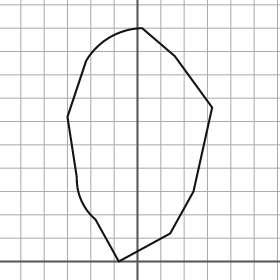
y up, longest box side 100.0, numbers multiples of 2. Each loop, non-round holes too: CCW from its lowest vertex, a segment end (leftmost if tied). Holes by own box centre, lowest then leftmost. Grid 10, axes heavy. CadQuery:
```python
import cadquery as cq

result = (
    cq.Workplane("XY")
    .moveTo(-8.0, 0.0)
    .lineTo(14.0, 12.0)
    .lineTo(24.0, 30.0)
    .lineTo(32.0, 66.0)
    .lineTo(16.0, 88.0)
    .lineTo(2.0, 100.0)
    .threePointArc((-12.0, 96.0), (-22.0, 86.0))
    .lineTo(-30.0, 62.0)
    .lineTo(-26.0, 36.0)
    .threePointArc((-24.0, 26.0), (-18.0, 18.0))
    .close()
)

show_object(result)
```